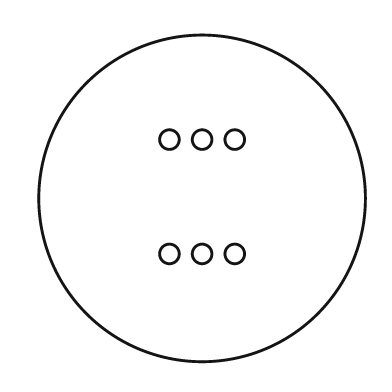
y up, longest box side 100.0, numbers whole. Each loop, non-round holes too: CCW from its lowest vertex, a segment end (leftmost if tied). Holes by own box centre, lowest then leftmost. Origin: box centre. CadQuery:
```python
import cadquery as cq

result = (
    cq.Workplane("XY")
    .moveTo(0.0, 0.0)
    .circle(50.0)
    .moveTo(-10.0, -17.0)
    .circle(3.0)
    .moveTo(0.0, -17.0)
    .circle(3.0)
    .moveTo(10.0, -17.0)
    .circle(3.0)
    .moveTo(-10.0, 18.0)
    .circle(3.0)
    .moveTo(0.0, 18.0)
    .circle(3.0)
    .moveTo(10.0, 18.0)
    .circle(3.0)
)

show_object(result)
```